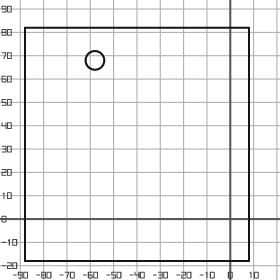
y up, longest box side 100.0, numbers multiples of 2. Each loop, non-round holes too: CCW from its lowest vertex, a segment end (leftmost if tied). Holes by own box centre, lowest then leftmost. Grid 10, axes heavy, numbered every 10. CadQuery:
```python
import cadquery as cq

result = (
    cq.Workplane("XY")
    .moveTo(-88.0, -18.0)
    .lineTo(8.0, -18.0)
    .lineTo(8.0, 82.0)
    .lineTo(-88.0, 82.0)
    .close()
    .moveTo(-58.0, 68.0)
    .circle(4.0)
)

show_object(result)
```